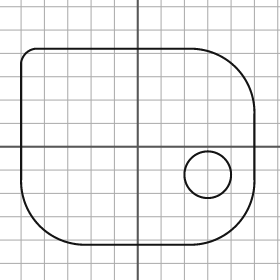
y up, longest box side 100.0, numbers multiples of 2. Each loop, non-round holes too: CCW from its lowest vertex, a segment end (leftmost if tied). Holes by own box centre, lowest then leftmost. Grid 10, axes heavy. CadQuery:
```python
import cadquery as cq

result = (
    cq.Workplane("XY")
    .moveTo(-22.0, -42.0)
    .lineTo(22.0, -42.0)
    .threePointArc((42.0, -34.0), (50.0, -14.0))
    .lineTo(50.0, 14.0)
    .threePointArc((42.0, 34.0), (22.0, 42.0))
    .lineTo(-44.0, 42.0)
    .threePointArc((-48.0, 40.0), (-50.0, 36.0))
    .lineTo(-50.0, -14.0)
    .threePointArc((-42.0, -34.0), (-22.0, -42.0))
    .close()
    .moveTo(30.0, -12.0)
    .circle(10.0)
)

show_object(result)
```